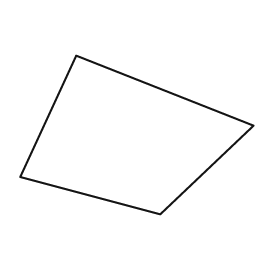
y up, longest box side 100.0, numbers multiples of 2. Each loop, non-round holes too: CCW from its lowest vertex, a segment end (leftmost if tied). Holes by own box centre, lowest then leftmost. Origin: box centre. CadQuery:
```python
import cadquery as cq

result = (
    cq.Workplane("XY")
    .moveTo(10.0, -34.0)
    .lineTo(50.0, 4.0)
    .lineTo(-26.0, 34.0)
    .lineTo(-50.0, -18.0)
    .close()
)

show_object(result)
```